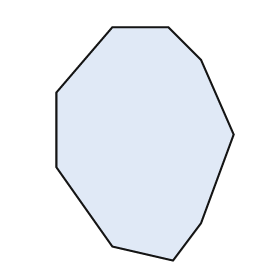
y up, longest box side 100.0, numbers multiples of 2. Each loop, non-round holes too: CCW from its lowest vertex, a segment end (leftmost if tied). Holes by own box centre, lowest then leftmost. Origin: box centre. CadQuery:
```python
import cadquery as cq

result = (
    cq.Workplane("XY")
    .moveTo(12.0, -50.0)
    .lineTo(24.0, -34.0)
    .lineTo(38.0, 4.0)
    .lineTo(24.0, 36.0)
    .lineTo(10.0, 50.0)
    .lineTo(-14.0, 50.0)
    .lineTo(-38.0, 22.0)
    .lineTo(-38.0, -10.0)
    .lineTo(-14.0, -44.0)
    .close()
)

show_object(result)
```